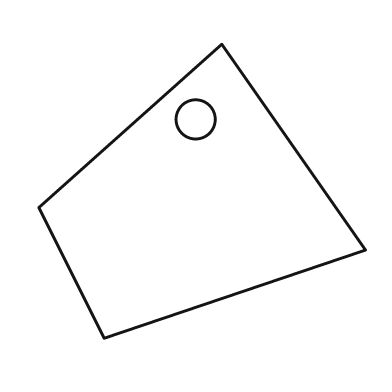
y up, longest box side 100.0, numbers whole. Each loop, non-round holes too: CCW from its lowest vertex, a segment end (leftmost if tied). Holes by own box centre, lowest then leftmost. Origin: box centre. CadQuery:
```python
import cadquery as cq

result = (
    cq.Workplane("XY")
    .moveTo(-30.0, -45.0)
    .lineTo(50.0, -18.0)
    .lineTo(6.0, 45.0)
    .lineTo(-50.0, -5.0)
    .close()
    .moveTo(-2.0, 22.0)
    .circle(6.0)
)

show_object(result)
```